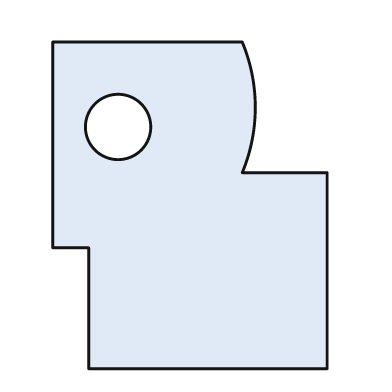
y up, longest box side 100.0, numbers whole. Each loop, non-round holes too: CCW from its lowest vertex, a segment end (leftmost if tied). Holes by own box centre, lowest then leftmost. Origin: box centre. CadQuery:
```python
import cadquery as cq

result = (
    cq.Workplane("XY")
    .moveTo(-31.0, -50.0)
    .lineTo(42.0, -50.0)
    .lineTo(42.0, 10.0)
    .lineTo(16.0, 10.0)
    .threePointArc((20.0, 30.0), (16.0, 50.0))
    .lineTo(-42.0, 50.0)
    .lineTo(-42.0, -13.0)
    .lineTo(-31.0, -13.0)
    .close()
    .moveTo(-22.0, 24.0)
    .circle(10.0)
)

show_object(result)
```